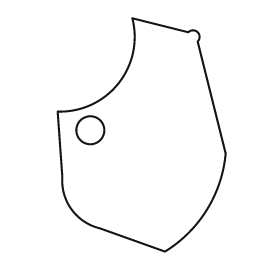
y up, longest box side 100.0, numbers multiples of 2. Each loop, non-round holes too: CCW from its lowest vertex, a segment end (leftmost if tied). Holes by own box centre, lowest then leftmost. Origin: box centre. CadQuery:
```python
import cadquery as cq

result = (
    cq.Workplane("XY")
    .moveTo(10.0, -50.0)
    .threePointArc((28.0, -32.0), (36.0, -8.0))
    .lineTo(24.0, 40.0)
    .threePointArc((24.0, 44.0), (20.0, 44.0))
    .lineTo(-4.0, 50.0)
    .threePointArc((-10.0, 22.0), (-36.0, 10.0))
    .lineTo(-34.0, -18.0)
    .threePointArc((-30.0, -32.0), (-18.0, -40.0))
    .close()
    .moveTo(-22.0, 2.0)
    .circle(6.0)
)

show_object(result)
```